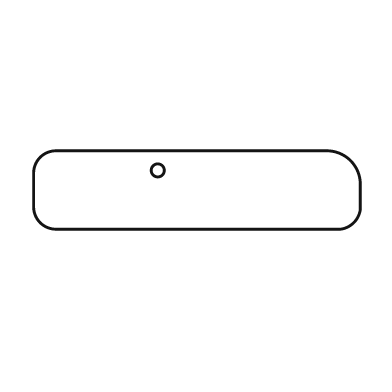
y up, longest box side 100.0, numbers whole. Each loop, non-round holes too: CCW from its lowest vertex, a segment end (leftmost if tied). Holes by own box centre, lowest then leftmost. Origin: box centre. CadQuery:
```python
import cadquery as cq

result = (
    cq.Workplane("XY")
    .moveTo(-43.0, -12.0)
    .lineTo(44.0, -12.0)
    .threePointArc((48.0, -10.0), (50.0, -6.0))
    .lineTo(50.0, 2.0)
    .threePointArc((47.0, 9.0), (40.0, 12.0))
    .lineTo(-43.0, 12.0)
    .threePointArc((-48.0, 10.0), (-50.0, 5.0))
    .lineTo(-50.0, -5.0)
    .threePointArc((-48.0, -10.0), (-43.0, -12.0))
    .close()
    .moveTo(-12.0, 6.0)
    .circle(2.0)
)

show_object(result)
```